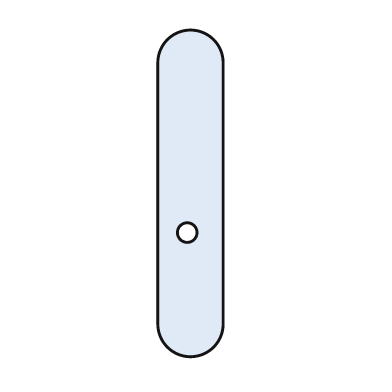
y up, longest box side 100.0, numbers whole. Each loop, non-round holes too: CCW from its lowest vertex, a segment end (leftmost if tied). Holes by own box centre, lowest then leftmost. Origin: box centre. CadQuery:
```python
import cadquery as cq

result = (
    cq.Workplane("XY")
    .moveTo(-10.0, -40.0)
    .threePointArc((0.0, -50.0), (10.0, -40.0))
    .lineTo(10.0, 40.0)
    .threePointArc((0.0, 50.0), (-10.0, 40.0))
    .close()
    .moveTo(-1.0, -12.0)
    .circle(3.0)
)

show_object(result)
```